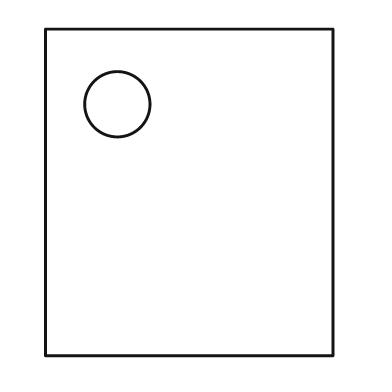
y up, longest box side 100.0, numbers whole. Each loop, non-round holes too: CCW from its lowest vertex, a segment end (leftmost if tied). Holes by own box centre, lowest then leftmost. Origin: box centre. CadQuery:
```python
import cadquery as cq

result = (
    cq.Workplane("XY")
    .moveTo(-44.0, -50.0)
    .lineTo(44.0, -50.0)
    .lineTo(44.0, 50.0)
    .lineTo(-44.0, 50.0)
    .close()
    .moveTo(-22.0, 27.0)
    .circle(10.0)
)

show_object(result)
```